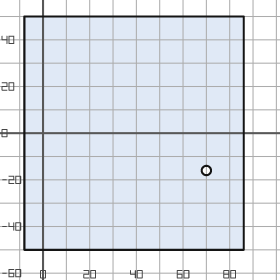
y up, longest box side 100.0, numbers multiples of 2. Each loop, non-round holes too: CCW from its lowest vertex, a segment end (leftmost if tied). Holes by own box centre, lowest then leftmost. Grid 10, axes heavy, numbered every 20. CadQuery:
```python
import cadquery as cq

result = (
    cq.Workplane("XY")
    .moveTo(-8.0, -50.0)
    .lineTo(86.0, -50.0)
    .lineTo(86.0, 50.0)
    .lineTo(-8.0, 50.0)
    .close()
    .moveTo(70.0, -16.0)
    .circle(2.0)
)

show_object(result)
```